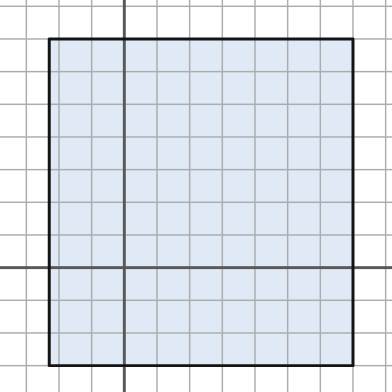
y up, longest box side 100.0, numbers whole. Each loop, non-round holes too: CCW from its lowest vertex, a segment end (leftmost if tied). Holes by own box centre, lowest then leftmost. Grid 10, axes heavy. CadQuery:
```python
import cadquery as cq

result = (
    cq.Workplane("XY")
    .moveTo(-23.0, -30.0)
    .lineTo(70.0, -30.0)
    .lineTo(70.0, 70.0)
    .lineTo(-23.0, 70.0)
    .close()
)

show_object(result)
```